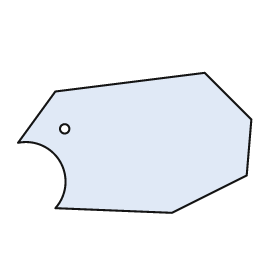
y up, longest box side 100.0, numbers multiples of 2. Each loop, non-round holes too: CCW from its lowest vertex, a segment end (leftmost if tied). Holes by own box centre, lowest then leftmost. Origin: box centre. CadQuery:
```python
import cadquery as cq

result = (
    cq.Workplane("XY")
    .moveTo(16.0, -30.0)
    .lineTo(48.0, -14.0)
    .lineTo(50.0, 10.0)
    .lineTo(30.0, 30.0)
    .lineTo(-34.0, 22.0)
    .lineTo(-50.0, 0.0)
    .threePointArc((-32.0, -8.0), (-34.0, -28.0))
    .close()
    .moveTo(-30.0, 6.0)
    .circle(2.0)
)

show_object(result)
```